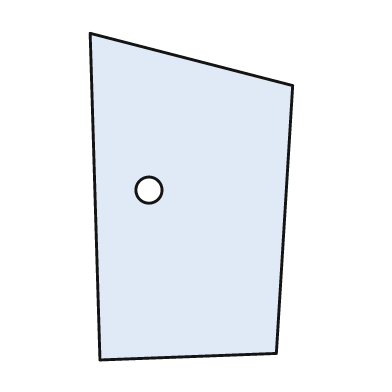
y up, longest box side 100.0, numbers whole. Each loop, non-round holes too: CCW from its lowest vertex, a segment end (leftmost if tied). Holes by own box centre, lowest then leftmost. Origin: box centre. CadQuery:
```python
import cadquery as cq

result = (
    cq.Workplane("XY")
    .moveTo(-28.0, -50.0)
    .lineTo(26.0, -48.0)
    .lineTo(31.0, 34.0)
    .lineTo(-31.0, 50.0)
    .close()
    .moveTo(-13.0, 2.0)
    .circle(4.0)
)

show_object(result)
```